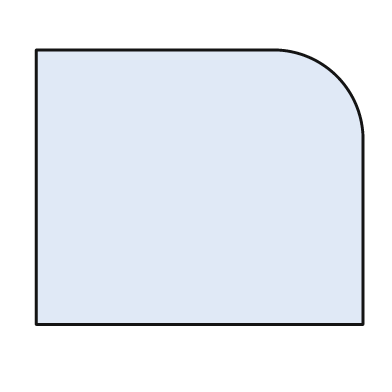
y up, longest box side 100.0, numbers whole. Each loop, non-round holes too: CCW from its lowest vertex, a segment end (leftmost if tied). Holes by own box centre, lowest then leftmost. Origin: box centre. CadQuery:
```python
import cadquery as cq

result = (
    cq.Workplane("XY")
    .moveTo(-50.0, -42.0)
    .lineTo(50.0, -42.0)
    .lineTo(50.0, 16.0)
    .threePointArc((42.0, 34.0), (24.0, 42.0))
    .lineTo(-50.0, 42.0)
    .close()
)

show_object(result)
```